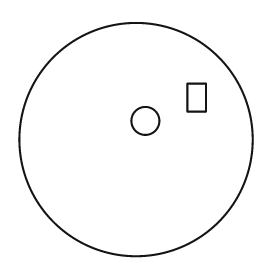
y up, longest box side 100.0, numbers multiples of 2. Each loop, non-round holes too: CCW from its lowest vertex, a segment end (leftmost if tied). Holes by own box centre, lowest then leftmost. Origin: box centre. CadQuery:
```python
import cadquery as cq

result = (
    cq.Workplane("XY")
    .moveTo(0.0, 0.0)
    .circle(50.0)
    .moveTo(4.0, 8.0)
    .circle(6.0)
    .moveTo(22.0, 12.0)
    .lineTo(30.0, 12.0)
    .lineTo(30.0, 24.0)
    .lineTo(22.0, 24.0)
    .close()
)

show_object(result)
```